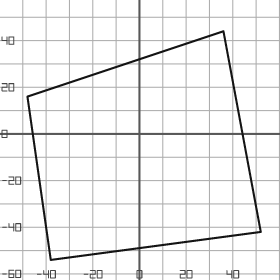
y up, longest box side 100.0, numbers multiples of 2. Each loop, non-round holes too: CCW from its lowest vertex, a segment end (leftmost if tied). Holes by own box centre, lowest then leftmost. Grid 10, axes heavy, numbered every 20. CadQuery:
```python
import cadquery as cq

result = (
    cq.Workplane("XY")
    .moveTo(-38.0, -54.0)
    .lineTo(52.0, -42.0)
    .lineTo(36.0, 44.0)
    .lineTo(-48.0, 16.0)
    .close()
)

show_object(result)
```